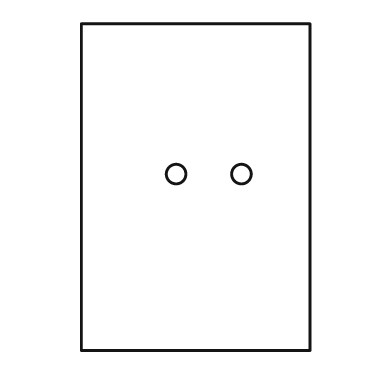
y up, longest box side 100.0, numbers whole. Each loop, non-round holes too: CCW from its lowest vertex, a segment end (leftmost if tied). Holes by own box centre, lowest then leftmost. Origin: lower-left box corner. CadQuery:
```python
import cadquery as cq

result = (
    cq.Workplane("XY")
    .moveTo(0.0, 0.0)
    .lineTo(70.0, 0.0)
    .lineTo(70.0, 100.0)
    .lineTo(0.0, 100.0)
    .close()
    .moveTo(29.0, 54.0)
    .circle(3.0)
    .moveTo(49.0, 54.0)
    .circle(3.0)
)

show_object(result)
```